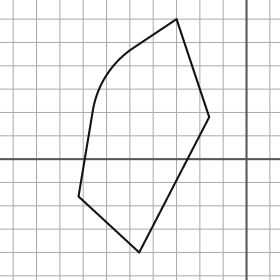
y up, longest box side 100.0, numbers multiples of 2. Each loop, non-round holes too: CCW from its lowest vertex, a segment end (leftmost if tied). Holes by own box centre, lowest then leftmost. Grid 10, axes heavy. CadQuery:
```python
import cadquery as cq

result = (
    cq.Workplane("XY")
    .moveTo(-46.0, -40.0)
    .lineTo(-16.0, 18.0)
    .lineTo(-30.0, 60.0)
    .lineTo(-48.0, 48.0)
    .threePointArc((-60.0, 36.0), (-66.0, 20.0))
    .lineTo(-72.0, -16.0)
    .close()
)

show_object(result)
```